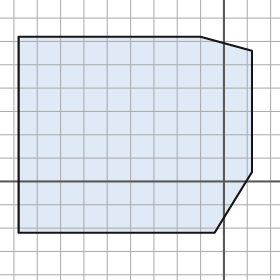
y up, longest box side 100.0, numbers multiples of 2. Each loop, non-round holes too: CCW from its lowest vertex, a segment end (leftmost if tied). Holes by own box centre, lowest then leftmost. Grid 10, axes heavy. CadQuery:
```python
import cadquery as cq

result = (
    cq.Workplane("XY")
    .moveTo(-88.0, -22.0)
    .lineTo(-4.0, -22.0)
    .lineTo(12.0, 4.0)
    .lineTo(12.0, 56.0)
    .lineTo(-10.0, 62.0)
    .lineTo(-88.0, 62.0)
    .close()
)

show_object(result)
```